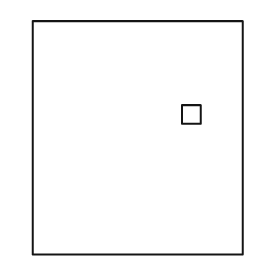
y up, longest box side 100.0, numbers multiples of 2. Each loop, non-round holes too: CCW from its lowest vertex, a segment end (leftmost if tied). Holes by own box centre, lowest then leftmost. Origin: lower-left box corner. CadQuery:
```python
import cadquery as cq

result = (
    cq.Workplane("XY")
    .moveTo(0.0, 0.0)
    .lineTo(90.0, 0.0)
    .lineTo(90.0, 100.0)
    .lineTo(0.0, 100.0)
    .close()
    .moveTo(64.0, 56.0)
    .lineTo(72.0, 56.0)
    .lineTo(72.0, 64.0)
    .lineTo(64.0, 64.0)
    .close()
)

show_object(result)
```